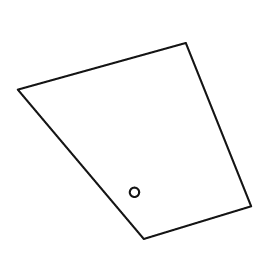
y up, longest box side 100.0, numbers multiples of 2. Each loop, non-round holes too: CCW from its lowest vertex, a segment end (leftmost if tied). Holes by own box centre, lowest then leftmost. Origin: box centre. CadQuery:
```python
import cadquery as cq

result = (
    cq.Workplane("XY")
    .moveTo(4.0, -42.0)
    .lineTo(50.0, -28.0)
    .lineTo(22.0, 42.0)
    .lineTo(-50.0, 22.0)
    .close()
    .moveTo(0.0, -22.0)
    .circle(2.0)
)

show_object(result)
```